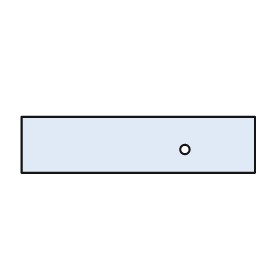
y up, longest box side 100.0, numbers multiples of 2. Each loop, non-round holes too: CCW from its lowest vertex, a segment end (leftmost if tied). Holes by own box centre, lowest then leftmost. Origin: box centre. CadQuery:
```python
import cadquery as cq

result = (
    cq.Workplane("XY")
    .moveTo(-50.0, -12.0)
    .lineTo(50.0, -12.0)
    .lineTo(50.0, 12.0)
    .lineTo(-50.0, 12.0)
    .close()
    .moveTo(20.0, -2.0)
    .circle(2.0)
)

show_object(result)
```